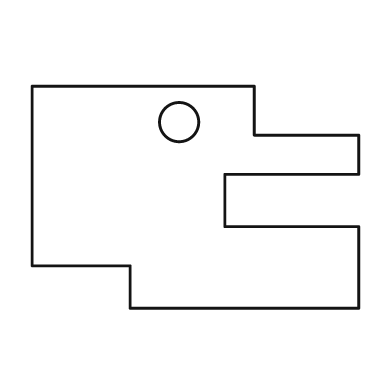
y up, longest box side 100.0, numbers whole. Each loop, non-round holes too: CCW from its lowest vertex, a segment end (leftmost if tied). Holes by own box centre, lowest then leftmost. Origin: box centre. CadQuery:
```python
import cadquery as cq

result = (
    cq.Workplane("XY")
    .moveTo(-20.0, -34.0)
    .lineTo(50.0, -34.0)
    .lineTo(50.0, -9.0)
    .lineTo(9.0, -9.0)
    .lineTo(9.0, 7.0)
    .lineTo(50.0, 7.0)
    .lineTo(50.0, 19.0)
    .lineTo(18.0, 19.0)
    .lineTo(18.0, 34.0)
    .lineTo(-50.0, 34.0)
    .lineTo(-50.0, -21.0)
    .lineTo(-20.0, -21.0)
    .close()
    .moveTo(-5.0, 23.0)
    .circle(6.0)
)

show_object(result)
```